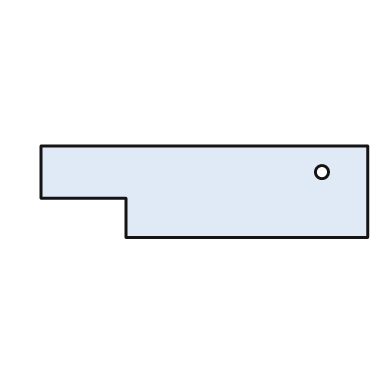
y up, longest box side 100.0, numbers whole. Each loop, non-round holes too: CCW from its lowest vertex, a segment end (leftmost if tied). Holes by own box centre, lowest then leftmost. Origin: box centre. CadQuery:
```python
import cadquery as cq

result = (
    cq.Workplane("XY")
    .moveTo(-24.0, -14.0)
    .lineTo(50.0, -14.0)
    .lineTo(50.0, 14.0)
    .lineTo(-50.0, 14.0)
    .lineTo(-50.0, -2.0)
    .lineTo(-24.0, -2.0)
    .close()
    .moveTo(36.0, 6.0)
    .circle(2.0)
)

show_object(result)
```